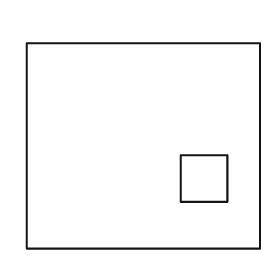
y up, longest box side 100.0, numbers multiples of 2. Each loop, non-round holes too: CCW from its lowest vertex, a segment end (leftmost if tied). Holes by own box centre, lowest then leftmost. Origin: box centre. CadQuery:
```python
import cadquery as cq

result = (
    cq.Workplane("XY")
    .moveTo(-50.0, -44.0)
    .lineTo(50.0, -44.0)
    .lineTo(50.0, 44.0)
    .lineTo(-50.0, 44.0)
    .close()
    .moveTo(16.0, -24.0)
    .lineTo(36.0, -24.0)
    .lineTo(36.0, -4.0)
    .lineTo(16.0, -4.0)
    .close()
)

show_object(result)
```